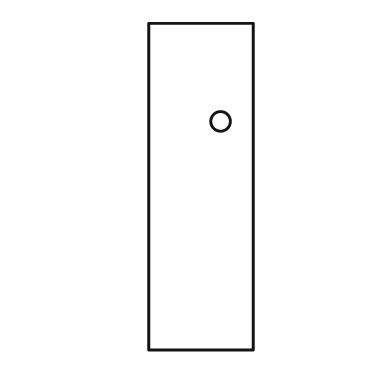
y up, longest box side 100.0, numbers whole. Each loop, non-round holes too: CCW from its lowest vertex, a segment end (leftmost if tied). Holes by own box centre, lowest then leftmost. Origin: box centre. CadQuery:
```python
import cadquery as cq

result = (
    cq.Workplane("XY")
    .moveTo(-16.0, -50.0)
    .lineTo(16.0, -50.0)
    .lineTo(16.0, 50.0)
    .lineTo(-16.0, 50.0)
    .close()
    .moveTo(6.0, 20.0)
    .circle(3.0)
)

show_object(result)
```